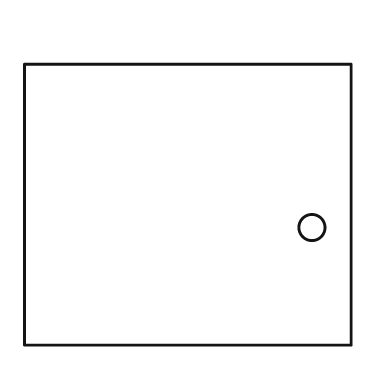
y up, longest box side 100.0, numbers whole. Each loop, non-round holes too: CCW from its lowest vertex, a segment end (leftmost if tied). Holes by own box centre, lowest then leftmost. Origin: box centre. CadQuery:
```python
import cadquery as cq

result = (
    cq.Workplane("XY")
    .moveTo(-50.0, -43.0)
    .lineTo(50.0, -43.0)
    .lineTo(50.0, 43.0)
    .lineTo(-50.0, 43.0)
    .close()
    .moveTo(38.0, -7.0)
    .circle(4.0)
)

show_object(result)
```